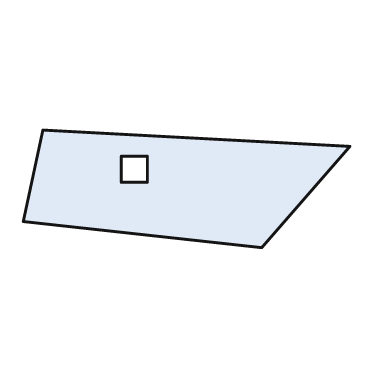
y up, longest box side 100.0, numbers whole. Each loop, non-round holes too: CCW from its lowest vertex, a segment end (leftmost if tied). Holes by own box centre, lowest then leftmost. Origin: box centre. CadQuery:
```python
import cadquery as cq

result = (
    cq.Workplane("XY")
    .moveTo(23.0, -18.0)
    .lineTo(50.0, 13.0)
    .lineTo(-44.0, 18.0)
    .lineTo(-50.0, -10.0)
    .close()
    .moveTo(-20.0, 2.0)
    .lineTo(-12.0, 2.0)
    .lineTo(-12.0, 10.0)
    .lineTo(-20.0, 10.0)
    .close()
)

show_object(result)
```